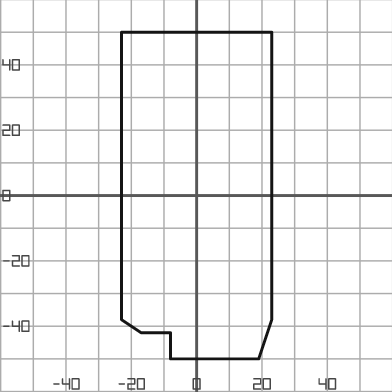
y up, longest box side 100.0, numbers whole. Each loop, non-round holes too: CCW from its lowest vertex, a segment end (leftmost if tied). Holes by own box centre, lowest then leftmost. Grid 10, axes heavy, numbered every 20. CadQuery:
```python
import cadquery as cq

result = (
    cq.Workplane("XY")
    .moveTo(-8.0, -50.0)
    .lineTo(19.0, -50.0)
    .lineTo(23.0, -38.0)
    .lineTo(23.0, 50.0)
    .lineTo(-23.0, 50.0)
    .lineTo(-23.0, -38.0)
    .lineTo(-17.0, -42.0)
    .lineTo(-8.0, -42.0)
    .close()
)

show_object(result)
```